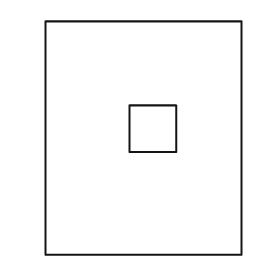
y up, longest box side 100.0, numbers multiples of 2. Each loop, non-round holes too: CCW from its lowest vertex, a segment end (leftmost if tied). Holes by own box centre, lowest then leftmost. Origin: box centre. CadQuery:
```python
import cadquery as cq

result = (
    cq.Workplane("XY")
    .moveTo(-42.0, -50.0)
    .lineTo(42.0, -50.0)
    .lineTo(42.0, 50.0)
    .lineTo(-42.0, 50.0)
    .close()
    .moveTo(-6.0, -6.0)
    .lineTo(14.0, -6.0)
    .lineTo(14.0, 14.0)
    .lineTo(-6.0, 14.0)
    .close()
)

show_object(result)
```